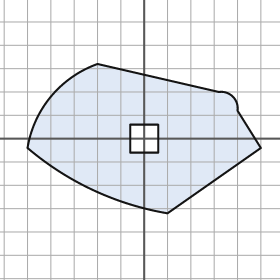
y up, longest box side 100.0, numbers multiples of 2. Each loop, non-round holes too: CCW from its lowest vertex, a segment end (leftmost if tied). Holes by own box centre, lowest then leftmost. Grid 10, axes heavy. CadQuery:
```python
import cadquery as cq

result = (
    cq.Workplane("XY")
    .moveTo(10.0, -32.0)
    .lineTo(50.0, -4.0)
    .lineTo(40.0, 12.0)
    .threePointArc((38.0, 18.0), (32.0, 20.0))
    .lineTo(-20.0, 32.0)
    .threePointArc((-40.0, 18.0), (-50.0, -4.0))
    .threePointArc((-22.0, -22.0), (10.0, -32.0))
    .close()
    .moveTo(-6.0, -6.0)
    .lineTo(6.0, -6.0)
    .lineTo(6.0, 6.0)
    .lineTo(-6.0, 6.0)
    .close()
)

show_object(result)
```